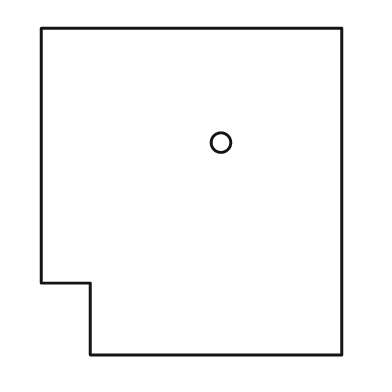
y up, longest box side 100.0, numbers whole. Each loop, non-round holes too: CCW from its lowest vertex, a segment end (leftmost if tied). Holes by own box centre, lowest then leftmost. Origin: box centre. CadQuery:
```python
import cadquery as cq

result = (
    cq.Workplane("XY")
    .moveTo(-31.0, -50.0)
    .lineTo(46.0, -50.0)
    .lineTo(46.0, 50.0)
    .lineTo(-46.0, 50.0)
    .lineTo(-46.0, -28.0)
    .lineTo(-31.0, -28.0)
    .close()
    .moveTo(9.0, 15.0)
    .circle(3.0)
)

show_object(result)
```